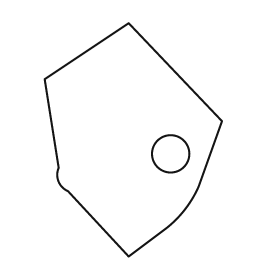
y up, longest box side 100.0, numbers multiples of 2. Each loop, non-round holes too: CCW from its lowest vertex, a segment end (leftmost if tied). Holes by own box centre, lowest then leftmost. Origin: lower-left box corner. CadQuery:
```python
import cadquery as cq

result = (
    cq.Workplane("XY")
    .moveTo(36.0, 0.0)
    .lineTo(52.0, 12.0)
    .threePointArc((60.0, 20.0), (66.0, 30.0))
    .lineTo(76.0, 58.0)
    .lineTo(36.0, 100.0)
    .lineTo(0.0, 76.0)
    .lineTo(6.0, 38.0)
    .threePointArc((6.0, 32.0), (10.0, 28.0))
    .close()
    .moveTo(54.0, 44.0)
    .circle(8.0)
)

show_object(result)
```